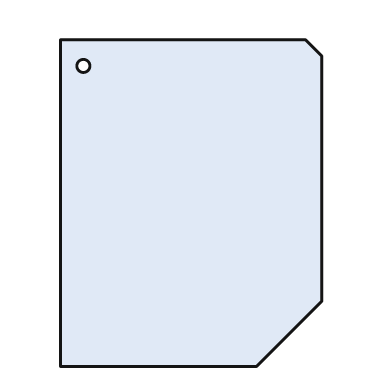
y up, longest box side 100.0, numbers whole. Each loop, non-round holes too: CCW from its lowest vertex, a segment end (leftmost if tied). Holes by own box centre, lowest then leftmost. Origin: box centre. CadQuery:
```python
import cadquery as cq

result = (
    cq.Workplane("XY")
    .moveTo(-40.0, -50.0)
    .lineTo(20.0, -50.0)
    .lineTo(40.0, -30.0)
    .lineTo(40.0, 45.0)
    .lineTo(35.0, 50.0)
    .lineTo(-40.0, 50.0)
    .close()
    .moveTo(-33.0, 42.0)
    .circle(2.0)
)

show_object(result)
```